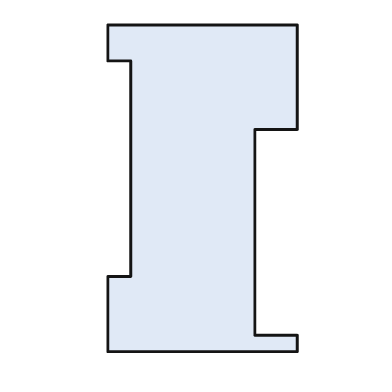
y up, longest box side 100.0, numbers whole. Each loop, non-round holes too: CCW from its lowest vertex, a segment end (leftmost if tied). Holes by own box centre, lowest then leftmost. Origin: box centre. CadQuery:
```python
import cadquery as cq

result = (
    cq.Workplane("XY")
    .moveTo(-29.0, -50.0)
    .lineTo(29.0, -50.0)
    .lineTo(29.0, -45.0)
    .lineTo(16.0, -45.0)
    .lineTo(16.0, 18.0)
    .lineTo(29.0, 18.0)
    .lineTo(29.0, 50.0)
    .lineTo(-29.0, 50.0)
    .lineTo(-29.0, 39.0)
    .lineTo(-22.0, 39.0)
    .lineTo(-22.0, -27.0)
    .lineTo(-29.0, -27.0)
    .close()
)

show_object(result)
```